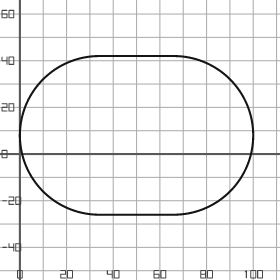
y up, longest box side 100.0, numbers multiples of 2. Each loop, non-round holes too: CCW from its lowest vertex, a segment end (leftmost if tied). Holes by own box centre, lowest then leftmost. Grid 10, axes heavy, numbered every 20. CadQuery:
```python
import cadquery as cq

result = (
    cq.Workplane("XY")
    .moveTo(34.0, -26.0)
    .lineTo(66.0, -26.0)
    .threePointArc((100.0, 8.0), (66.0, 42.0))
    .lineTo(34.0, 42.0)
    .threePointArc((0.0, 8.0), (34.0, -26.0))
    .close()
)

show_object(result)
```